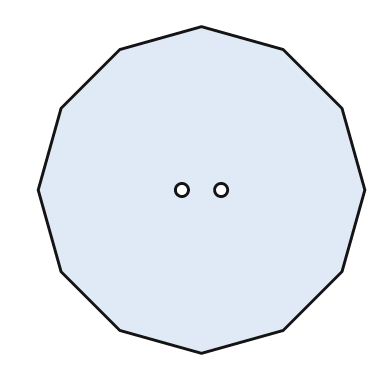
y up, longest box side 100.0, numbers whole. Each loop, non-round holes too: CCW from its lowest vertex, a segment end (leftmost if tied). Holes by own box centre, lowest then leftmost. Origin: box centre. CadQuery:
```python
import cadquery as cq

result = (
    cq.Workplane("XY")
    .moveTo(0.0, -50.0)
    .lineTo(25.0, -43.0)
    .lineTo(43.0, -25.0)
    .lineTo(50.0, 0.0)
    .lineTo(43.0, 25.0)
    .lineTo(25.0, 43.0)
    .lineTo(0.0, 50.0)
    .lineTo(-25.0, 43.0)
    .lineTo(-43.0, 25.0)
    .lineTo(-50.0, 0.0)
    .lineTo(-43.0, -25.0)
    .lineTo(-25.0, -43.0)
    .close()
    .moveTo(-6.0, 0.0)
    .circle(2.0)
    .moveTo(6.0, 0.0)
    .circle(2.0)
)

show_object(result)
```